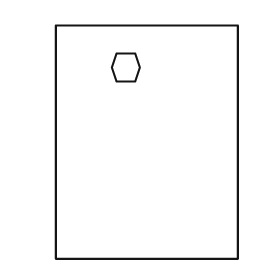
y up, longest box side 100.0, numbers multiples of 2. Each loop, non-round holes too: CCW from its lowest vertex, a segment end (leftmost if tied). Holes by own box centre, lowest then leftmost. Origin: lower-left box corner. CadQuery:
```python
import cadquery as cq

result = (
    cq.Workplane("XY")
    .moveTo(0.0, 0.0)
    .lineTo(78.0, 0.0)
    .lineTo(78.0, 100.0)
    .lineTo(0.0, 100.0)
    .close()
    .moveTo(26.0, 76.0)
    .lineTo(34.0, 76.0)
    .lineTo(36.0, 82.0)
    .lineTo(34.0, 88.0)
    .lineTo(26.0, 88.0)
    .lineTo(24.0, 82.0)
    .close()
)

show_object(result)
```